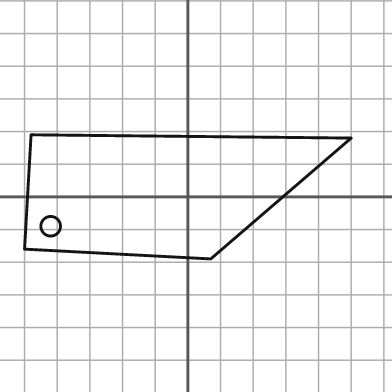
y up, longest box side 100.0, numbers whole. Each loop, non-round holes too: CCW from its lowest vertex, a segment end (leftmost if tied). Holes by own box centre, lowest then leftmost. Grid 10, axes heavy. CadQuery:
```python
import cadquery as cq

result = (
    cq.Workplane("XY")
    .moveTo(7.0, -19.0)
    .lineTo(50.0, 18.0)
    .lineTo(-48.0, 19.0)
    .lineTo(-50.0, -16.0)
    .close()
    .moveTo(-42.0, -9.0)
    .circle(3.0)
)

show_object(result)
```